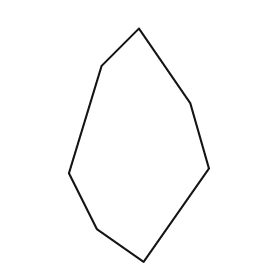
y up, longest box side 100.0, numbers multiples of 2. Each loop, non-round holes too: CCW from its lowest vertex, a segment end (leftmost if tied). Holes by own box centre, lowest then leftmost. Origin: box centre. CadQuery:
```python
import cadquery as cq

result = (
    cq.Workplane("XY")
    .moveTo(2.0, -50.0)
    .lineTo(30.0, -10.0)
    .lineTo(22.0, 18.0)
    .lineTo(0.0, 50.0)
    .lineTo(-16.0, 34.0)
    .lineTo(-30.0, -12.0)
    .lineTo(-18.0, -36.0)
    .close()
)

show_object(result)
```